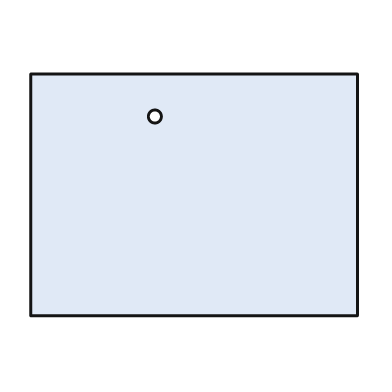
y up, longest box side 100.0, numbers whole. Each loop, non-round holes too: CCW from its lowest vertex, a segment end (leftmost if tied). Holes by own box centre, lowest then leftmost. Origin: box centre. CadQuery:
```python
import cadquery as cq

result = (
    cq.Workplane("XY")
    .moveTo(-50.0, -37.0)
    .lineTo(50.0, -37.0)
    .lineTo(50.0, 37.0)
    .lineTo(-50.0, 37.0)
    .close()
    .moveTo(-12.0, 24.0)
    .circle(2.0)
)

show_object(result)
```